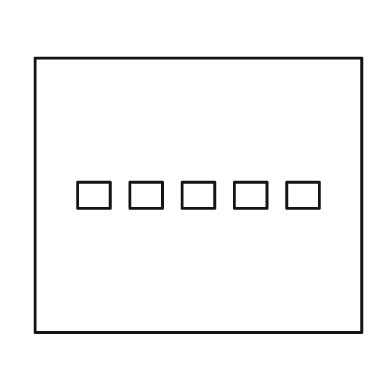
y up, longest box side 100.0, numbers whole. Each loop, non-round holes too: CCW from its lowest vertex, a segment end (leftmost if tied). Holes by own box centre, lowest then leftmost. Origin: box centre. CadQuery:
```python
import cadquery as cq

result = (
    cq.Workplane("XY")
    .moveTo(-50.0, -42.0)
    .lineTo(50.0, -42.0)
    .lineTo(50.0, 42.0)
    .lineTo(-50.0, 42.0)
    .close()
    .moveTo(-37.0, -4.0)
    .lineTo(-27.0, -4.0)
    .lineTo(-27.0, 4.0)
    .lineTo(-37.0, 4.0)
    .close()
    .moveTo(-21.0, -4.0)
    .lineTo(-11.0, -4.0)
    .lineTo(-11.0, 4.0)
    .lineTo(-21.0, 4.0)
    .close()
    .moveTo(-5.0, -4.0)
    .lineTo(5.0, -4.0)
    .lineTo(5.0, 4.0)
    .lineTo(-5.0, 4.0)
    .close()
    .moveTo(11.0, -4.0)
    .lineTo(21.0, -4.0)
    .lineTo(21.0, 4.0)
    .lineTo(11.0, 4.0)
    .close()
    .moveTo(27.0, -4.0)
    .lineTo(37.0, -4.0)
    .lineTo(37.0, 4.0)
    .lineTo(27.0, 4.0)
    .close()
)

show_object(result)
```